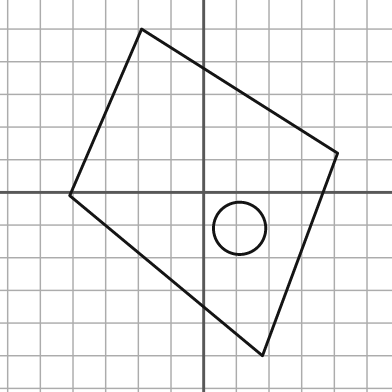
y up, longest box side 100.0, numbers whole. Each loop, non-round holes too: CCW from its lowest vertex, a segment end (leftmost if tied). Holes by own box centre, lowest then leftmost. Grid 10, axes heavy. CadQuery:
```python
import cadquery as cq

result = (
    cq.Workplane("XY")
    .moveTo(18.0, -50.0)
    .lineTo(41.0, 12.0)
    .lineTo(-19.0, 50.0)
    .lineTo(-41.0, -1.0)
    .close()
    .moveTo(11.0, -11.0)
    .circle(8.0)
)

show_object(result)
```